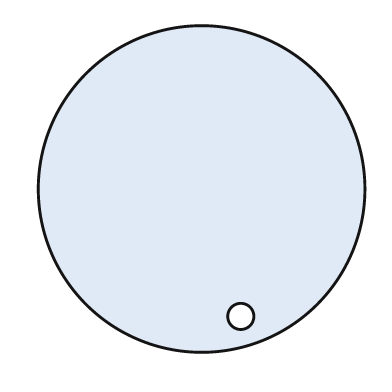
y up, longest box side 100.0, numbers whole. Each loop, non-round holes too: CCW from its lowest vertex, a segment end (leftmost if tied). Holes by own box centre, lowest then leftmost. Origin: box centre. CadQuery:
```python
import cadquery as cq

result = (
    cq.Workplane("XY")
    .moveTo(0.0, 0.0)
    .circle(50.0)
    .moveTo(12.0, -39.0)
    .circle(4.0)
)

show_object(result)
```